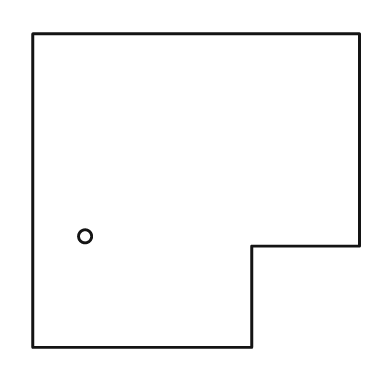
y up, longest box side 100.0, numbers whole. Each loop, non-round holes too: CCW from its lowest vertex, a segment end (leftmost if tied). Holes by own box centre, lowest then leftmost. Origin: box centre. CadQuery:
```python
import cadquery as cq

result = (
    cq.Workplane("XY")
    .moveTo(-50.0, -48.0)
    .lineTo(17.0, -48.0)
    .lineTo(17.0, -17.0)
    .lineTo(50.0, -17.0)
    .lineTo(50.0, 48.0)
    .lineTo(-50.0, 48.0)
    .close()
    .moveTo(-34.0, -14.0)
    .circle(2.0)
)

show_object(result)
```